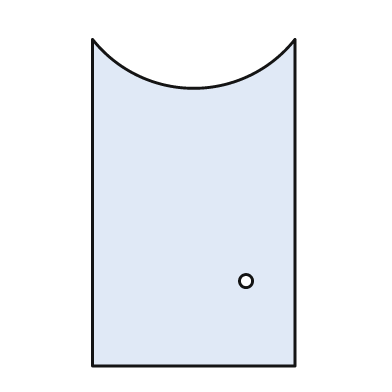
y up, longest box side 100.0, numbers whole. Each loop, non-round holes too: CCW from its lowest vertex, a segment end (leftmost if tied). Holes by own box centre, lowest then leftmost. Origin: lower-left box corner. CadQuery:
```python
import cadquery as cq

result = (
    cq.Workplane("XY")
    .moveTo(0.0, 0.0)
    .lineTo(62.0, 0.0)
    .lineTo(62.0, 100.0)
    .threePointArc((31.0, 85.0), (0.0, 100.0))
    .close()
    .moveTo(47.0, 26.0)
    .circle(2.0)
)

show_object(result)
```